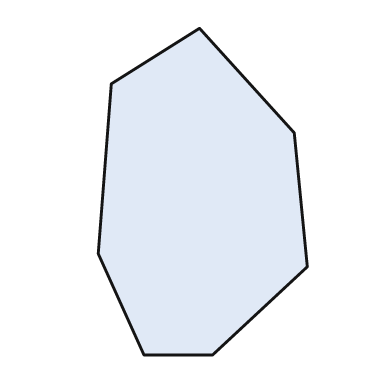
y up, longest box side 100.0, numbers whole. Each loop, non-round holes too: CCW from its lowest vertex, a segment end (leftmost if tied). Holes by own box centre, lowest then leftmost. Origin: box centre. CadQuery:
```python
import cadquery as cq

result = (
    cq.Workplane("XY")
    .moveTo(-18.0, -50.0)
    .lineTo(3.0, -50.0)
    .lineTo(32.0, -23.0)
    .lineTo(28.0, 18.0)
    .lineTo(-1.0, 50.0)
    .lineTo(-28.0, 33.0)
    .lineTo(-32.0, -19.0)
    .close()
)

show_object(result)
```